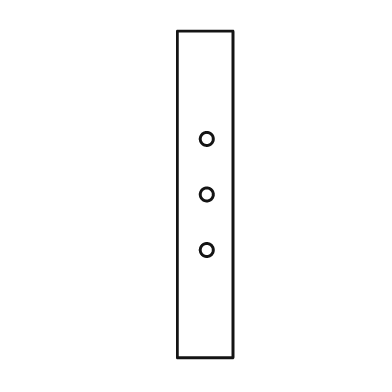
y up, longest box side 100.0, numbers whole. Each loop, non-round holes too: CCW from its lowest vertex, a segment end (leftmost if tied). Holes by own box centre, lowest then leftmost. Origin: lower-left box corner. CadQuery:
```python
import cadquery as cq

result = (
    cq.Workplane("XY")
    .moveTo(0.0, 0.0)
    .lineTo(17.0, 0.0)
    .lineTo(17.0, 100.0)
    .lineTo(0.0, 100.0)
    .close()
    .moveTo(9.0, 33.0)
    .circle(2.0)
    .moveTo(9.0, 50.0)
    .circle(2.0)
    .moveTo(9.0, 67.0)
    .circle(2.0)
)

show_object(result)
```